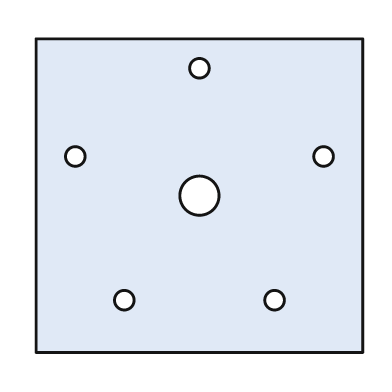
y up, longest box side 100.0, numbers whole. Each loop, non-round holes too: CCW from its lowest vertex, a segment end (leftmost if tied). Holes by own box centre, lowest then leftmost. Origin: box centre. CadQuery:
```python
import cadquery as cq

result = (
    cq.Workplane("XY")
    .moveTo(-50.0, -48.0)
    .lineTo(50.0, -48.0)
    .lineTo(50.0, 48.0)
    .lineTo(-50.0, 48.0)
    .close()
    .moveTo(-23.0, -32.0)
    .circle(3.0)
    .moveTo(23.0, -32.0)
    .circle(3.0)
    .moveTo(0.0, 0.0)
    .circle(6.0)
    .moveTo(-38.0, 12.0)
    .circle(3.0)
    .moveTo(38.0, 12.0)
    .circle(3.0)
    .moveTo(0.0, 39.0)
    .circle(3.0)
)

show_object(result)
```